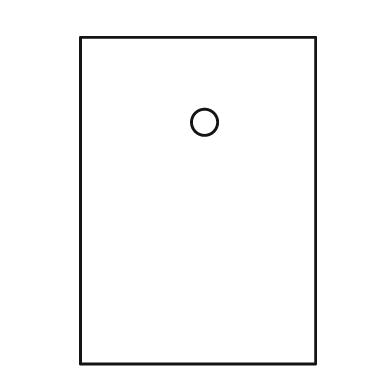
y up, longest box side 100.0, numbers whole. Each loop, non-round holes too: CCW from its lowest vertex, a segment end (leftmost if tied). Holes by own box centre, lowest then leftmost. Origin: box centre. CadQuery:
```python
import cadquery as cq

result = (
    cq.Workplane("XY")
    .moveTo(-36.0, -50.0)
    .lineTo(36.0, -50.0)
    .lineTo(36.0, 50.0)
    .lineTo(-36.0, 50.0)
    .close()
    .moveTo(2.0, 24.0)
    .circle(4.0)
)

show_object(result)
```